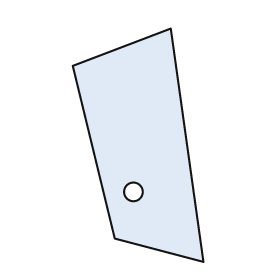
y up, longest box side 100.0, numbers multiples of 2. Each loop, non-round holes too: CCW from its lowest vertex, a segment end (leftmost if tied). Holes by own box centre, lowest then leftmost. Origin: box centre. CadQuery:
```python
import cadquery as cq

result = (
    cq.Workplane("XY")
    .moveTo(28.0, -50.0)
    .lineTo(14.0, 50.0)
    .lineTo(-28.0, 34.0)
    .lineTo(-10.0, -40.0)
    .close()
    .moveTo(-2.0, -20.0)
    .circle(4.0)
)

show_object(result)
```